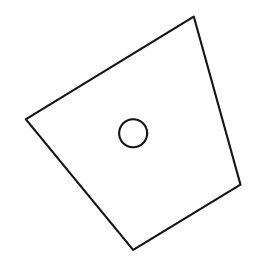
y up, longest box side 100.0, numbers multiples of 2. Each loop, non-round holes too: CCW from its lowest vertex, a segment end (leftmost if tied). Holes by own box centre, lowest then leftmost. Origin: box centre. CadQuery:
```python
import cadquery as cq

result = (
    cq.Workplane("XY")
    .moveTo(0.0, -50.0)
    .lineTo(46.0, -22.0)
    .lineTo(26.0, 50.0)
    .lineTo(-46.0, 6.0)
    .close()
    .moveTo(0.0, 0.0)
    .circle(6.0)
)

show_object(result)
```